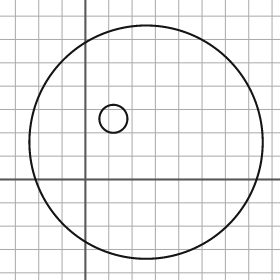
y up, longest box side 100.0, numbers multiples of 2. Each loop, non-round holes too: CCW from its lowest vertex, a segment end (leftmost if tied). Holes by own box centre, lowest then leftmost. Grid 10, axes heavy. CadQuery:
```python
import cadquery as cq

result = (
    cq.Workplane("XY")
    .moveTo(26.0, 16.0)
    .circle(50.0)
    .moveTo(12.0, 26.0)
    .circle(6.0)
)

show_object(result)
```